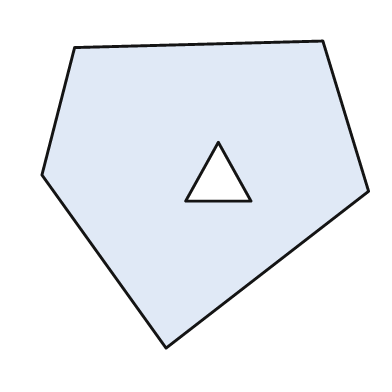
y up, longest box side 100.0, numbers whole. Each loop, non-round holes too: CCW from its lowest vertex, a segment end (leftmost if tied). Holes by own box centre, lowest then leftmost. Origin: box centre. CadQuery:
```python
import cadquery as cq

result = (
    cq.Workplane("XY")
    .moveTo(-12.0, -47.0)
    .lineTo(50.0, 1.0)
    .lineTo(36.0, 47.0)
    .lineTo(-40.0, 45.0)
    .lineTo(-50.0, 6.0)
    .close()
    .moveTo(-6.0, -2.0)
    .lineTo(14.0, -2.0)
    .lineTo(4.0, 16.0)
    .close()
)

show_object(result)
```